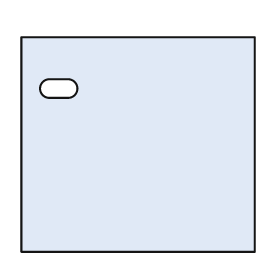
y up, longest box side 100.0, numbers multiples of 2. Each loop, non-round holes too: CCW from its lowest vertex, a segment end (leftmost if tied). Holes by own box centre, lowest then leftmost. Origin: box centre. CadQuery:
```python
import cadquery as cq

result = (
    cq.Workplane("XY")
    .moveTo(-50.0, -46.0)
    .lineTo(50.0, -46.0)
    .lineTo(50.0, 46.0)
    .lineTo(-50.0, 46.0)
    .close()
    .moveTo(-38.0, 20.0)
    .lineTo(-30.0, 20.0)
    .threePointArc((-26.0, 24.0), (-30.0, 28.0))
    .lineTo(-38.0, 28.0)
    .threePointArc((-42.0, 24.0), (-38.0, 20.0))
    .close()
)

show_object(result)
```